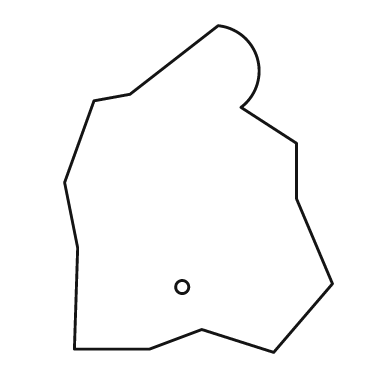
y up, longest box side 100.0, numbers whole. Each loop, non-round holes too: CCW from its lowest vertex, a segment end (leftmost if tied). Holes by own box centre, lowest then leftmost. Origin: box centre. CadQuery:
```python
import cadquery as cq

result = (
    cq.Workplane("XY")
    .moveTo(23.0, -50.0)
    .lineTo(41.0, -29.0)
    .lineTo(30.0, -3.0)
    .lineTo(30.0, 14.0)
    .lineTo(13.0, 25.0)
    .threePointArc((18.0, 40.0), (6.0, 50.0))
    .lineTo(-21.0, 29.0)
    .lineTo(-32.0, 27.0)
    .lineTo(-41.0, 2.0)
    .lineTo(-37.0, -18.0)
    .lineTo(-38.0, -49.0)
    .lineTo(-15.0, -49.0)
    .lineTo(1.0, -43.0)
    .close()
    .moveTo(-5.0, -30.0)
    .circle(2.0)
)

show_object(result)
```